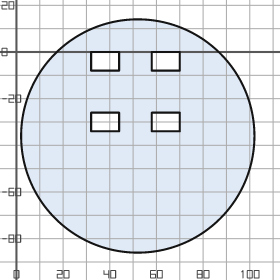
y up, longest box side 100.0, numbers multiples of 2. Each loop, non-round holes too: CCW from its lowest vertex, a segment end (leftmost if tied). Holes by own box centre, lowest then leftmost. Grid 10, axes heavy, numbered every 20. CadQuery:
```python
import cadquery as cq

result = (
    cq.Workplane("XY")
    .moveTo(52.0, -36.0)
    .circle(50.0)
    .moveTo(32.0, -34.0)
    .lineTo(44.0, -34.0)
    .lineTo(44.0, -26.0)
    .lineTo(32.0, -26.0)
    .close()
    .moveTo(58.0, -34.0)
    .lineTo(70.0, -34.0)
    .lineTo(70.0, -26.0)
    .lineTo(58.0, -26.0)
    .close()
    .moveTo(32.0, -8.0)
    .lineTo(44.0, -8.0)
    .lineTo(44.0, 0.0)
    .lineTo(32.0, 0.0)
    .close()
    .moveTo(58.0, -8.0)
    .lineTo(70.0, -8.0)
    .lineTo(70.0, 0.0)
    .lineTo(58.0, 0.0)
    .close()
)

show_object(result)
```